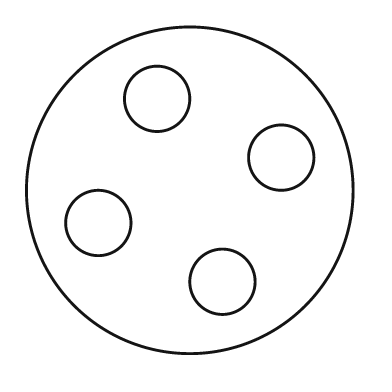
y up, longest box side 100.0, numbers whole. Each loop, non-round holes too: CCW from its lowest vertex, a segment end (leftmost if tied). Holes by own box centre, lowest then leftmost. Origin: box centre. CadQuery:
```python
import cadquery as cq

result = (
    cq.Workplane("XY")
    .moveTo(0.0, 0.0)
    .circle(50.0)
    .moveTo(10.0, -28.0)
    .circle(10.0)
    .moveTo(-28.0, -10.0)
    .circle(10.0)
    .moveTo(28.0, 10.0)
    .circle(10.0)
    .moveTo(-10.0, 28.0)
    .circle(10.0)
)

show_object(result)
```